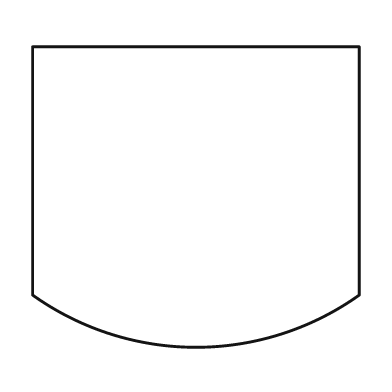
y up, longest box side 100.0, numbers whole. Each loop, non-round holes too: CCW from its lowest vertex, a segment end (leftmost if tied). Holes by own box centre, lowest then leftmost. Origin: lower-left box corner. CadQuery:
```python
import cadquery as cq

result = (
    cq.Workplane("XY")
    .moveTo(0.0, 16.0)
    .threePointArc((50.0, 0.0), (100.0, 16.0))
    .lineTo(100.0, 92.0)
    .lineTo(0.0, 92.0)
    .close()
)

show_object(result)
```